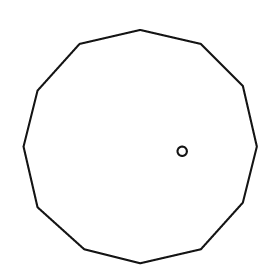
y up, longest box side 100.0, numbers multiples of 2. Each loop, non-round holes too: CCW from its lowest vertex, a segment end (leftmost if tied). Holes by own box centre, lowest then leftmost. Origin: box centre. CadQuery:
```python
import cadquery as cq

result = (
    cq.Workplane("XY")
    .moveTo(0.0, -50.0)
    .lineTo(26.0, -44.0)
    .lineTo(44.0, -24.0)
    .lineTo(50.0, 0.0)
    .lineTo(44.0, 26.0)
    .lineTo(26.0, 44.0)
    .lineTo(0.0, 50.0)
    .lineTo(-26.0, 44.0)
    .lineTo(-44.0, 24.0)
    .lineTo(-50.0, 0.0)
    .lineTo(-44.0, -26.0)
    .lineTo(-24.0, -44.0)
    .close()
    .moveTo(18.0, -2.0)
    .circle(2.0)
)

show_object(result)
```